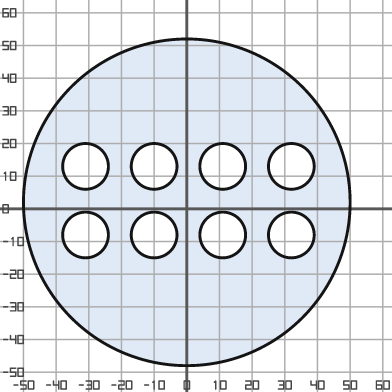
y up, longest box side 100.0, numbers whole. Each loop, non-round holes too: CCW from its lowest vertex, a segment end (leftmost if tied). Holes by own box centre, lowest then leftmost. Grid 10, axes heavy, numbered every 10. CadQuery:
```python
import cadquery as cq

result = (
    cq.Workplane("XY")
    .moveTo(0.0, 2.0)
    .circle(50.0)
    .moveTo(-31.0, -8.0)
    .circle(7.0)
    .moveTo(-10.0, -8.0)
    .circle(7.0)
    .moveTo(11.0, -8.0)
    .circle(7.0)
    .moveTo(32.0, -8.0)
    .circle(7.0)
    .moveTo(-31.0, 13.0)
    .circle(7.0)
    .moveTo(-10.0, 13.0)
    .circle(7.0)
    .moveTo(11.0, 13.0)
    .circle(7.0)
    .moveTo(32.0, 13.0)
    .circle(7.0)
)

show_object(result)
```